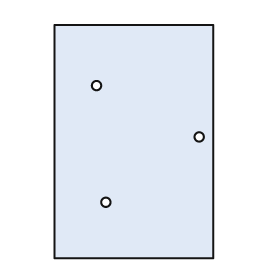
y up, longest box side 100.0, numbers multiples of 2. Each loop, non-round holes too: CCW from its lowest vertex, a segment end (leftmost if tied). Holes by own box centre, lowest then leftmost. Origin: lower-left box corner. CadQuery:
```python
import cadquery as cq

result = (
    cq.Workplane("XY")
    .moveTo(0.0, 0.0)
    .lineTo(68.0, 0.0)
    .lineTo(68.0, 100.0)
    .lineTo(0.0, 100.0)
    .close()
    .moveTo(22.0, 24.0)
    .circle(2.0)
    .moveTo(62.0, 52.0)
    .circle(2.0)
    .moveTo(18.0, 74.0)
    .circle(2.0)
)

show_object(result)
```